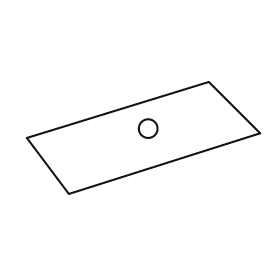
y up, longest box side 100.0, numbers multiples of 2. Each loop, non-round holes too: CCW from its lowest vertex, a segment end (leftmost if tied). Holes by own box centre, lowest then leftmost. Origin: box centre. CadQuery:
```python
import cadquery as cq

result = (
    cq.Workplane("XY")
    .moveTo(-32.0, -24.0)
    .lineTo(50.0, 2.0)
    .lineTo(28.0, 24.0)
    .lineTo(-50.0, 0.0)
    .close()
    .moveTo(2.0, 4.0)
    .circle(4.0)
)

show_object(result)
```